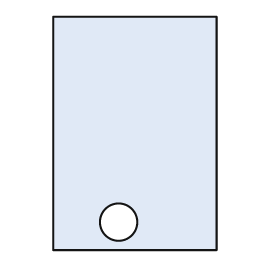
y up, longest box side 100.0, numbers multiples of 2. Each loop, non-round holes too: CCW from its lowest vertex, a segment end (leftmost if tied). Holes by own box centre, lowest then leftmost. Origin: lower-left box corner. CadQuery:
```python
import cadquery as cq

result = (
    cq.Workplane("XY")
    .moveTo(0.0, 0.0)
    .lineTo(70.0, 0.0)
    .lineTo(70.0, 100.0)
    .lineTo(0.0, 100.0)
    .close()
    .moveTo(28.0, 12.0)
    .circle(8.0)
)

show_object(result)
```